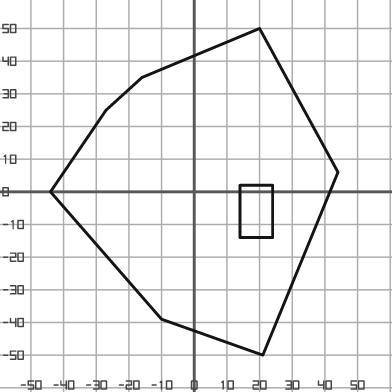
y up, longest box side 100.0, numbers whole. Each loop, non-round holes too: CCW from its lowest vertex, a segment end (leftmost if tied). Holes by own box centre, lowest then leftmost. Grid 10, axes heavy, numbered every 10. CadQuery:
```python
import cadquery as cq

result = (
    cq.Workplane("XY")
    .moveTo(21.0, -50.0)
    .lineTo(44.0, 6.0)
    .lineTo(20.0, 50.0)
    .lineTo(-16.0, 35.0)
    .lineTo(-27.0, 25.0)
    .lineTo(-44.0, 0.0)
    .lineTo(-10.0, -39.0)
    .close()
    .moveTo(14.0, -14.0)
    .lineTo(24.0, -14.0)
    .lineTo(24.0, 2.0)
    .lineTo(14.0, 2.0)
    .close()
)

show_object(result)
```